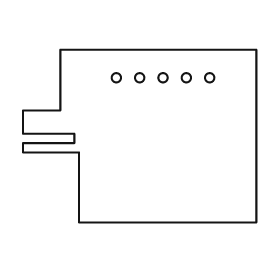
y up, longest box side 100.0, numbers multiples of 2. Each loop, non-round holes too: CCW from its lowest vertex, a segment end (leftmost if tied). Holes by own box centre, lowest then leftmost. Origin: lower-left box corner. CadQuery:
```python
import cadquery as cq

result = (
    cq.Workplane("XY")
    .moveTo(24.0, 0.0)
    .lineTo(100.0, 0.0)
    .lineTo(100.0, 74.0)
    .lineTo(16.0, 74.0)
    .lineTo(16.0, 48.0)
    .lineTo(0.0, 48.0)
    .lineTo(0.0, 38.0)
    .lineTo(22.0, 38.0)
    .lineTo(22.0, 34.0)
    .lineTo(0.0, 34.0)
    .lineTo(0.0, 30.0)
    .lineTo(24.0, 30.0)
    .close()
    .moveTo(40.0, 62.0)
    .circle(2.0)
    .moveTo(50.0, 62.0)
    .circle(2.0)
    .moveTo(60.0, 62.0)
    .circle(2.0)
    .moveTo(70.0, 62.0)
    .circle(2.0)
    .moveTo(80.0, 62.0)
    .circle(2.0)
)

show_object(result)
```